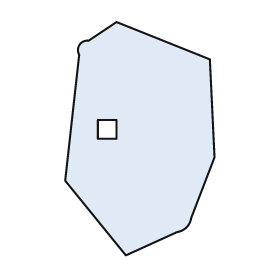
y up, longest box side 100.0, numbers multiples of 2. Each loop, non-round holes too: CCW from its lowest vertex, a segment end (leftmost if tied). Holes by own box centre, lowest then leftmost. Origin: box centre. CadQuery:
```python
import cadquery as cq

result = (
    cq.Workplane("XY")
    .moveTo(-6.0, -50.0)
    .lineTo(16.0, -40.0)
    .threePointArc((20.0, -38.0), (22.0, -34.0))
    .lineTo(32.0, -8.0)
    .lineTo(30.0, 34.0)
    .lineTo(-10.0, 50.0)
    .lineTo(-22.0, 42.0)
    .threePointArc((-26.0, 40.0), (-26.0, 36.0))
    .lineTo(-32.0, -18.0)
    .close()
    .moveTo(-18.0, 0.0)
    .lineTo(-10.0, 0.0)
    .lineTo(-10.0, 8.0)
    .lineTo(-18.0, 8.0)
    .close()
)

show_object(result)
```